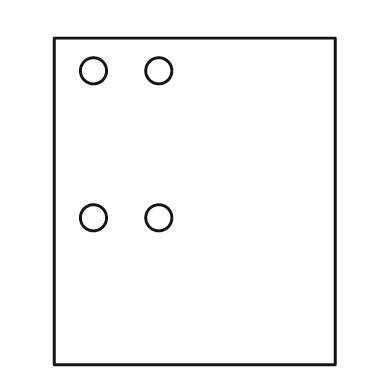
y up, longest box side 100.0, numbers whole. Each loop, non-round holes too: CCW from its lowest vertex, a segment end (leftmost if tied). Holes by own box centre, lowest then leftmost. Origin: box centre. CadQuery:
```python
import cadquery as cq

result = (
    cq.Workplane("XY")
    .moveTo(-43.0, -50.0)
    .lineTo(43.0, -50.0)
    .lineTo(43.0, 50.0)
    .lineTo(-43.0, 50.0)
    .close()
    .moveTo(-31.0, -5.0)
    .circle(4.0)
    .moveTo(-11.0, -5.0)
    .circle(4.0)
    .moveTo(-31.0, 40.0)
    .circle(4.0)
    .moveTo(-11.0, 40.0)
    .circle(4.0)
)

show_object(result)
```